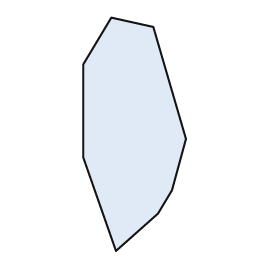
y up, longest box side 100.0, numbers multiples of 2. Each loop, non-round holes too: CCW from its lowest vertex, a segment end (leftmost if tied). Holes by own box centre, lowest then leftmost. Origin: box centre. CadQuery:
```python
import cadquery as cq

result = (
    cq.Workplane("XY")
    .moveTo(-8.0, -50.0)
    .lineTo(10.0, -34.0)
    .lineTo(16.0, -24.0)
    .lineTo(22.0, -2.0)
    .lineTo(8.0, 46.0)
    .lineTo(-10.0, 50.0)
    .lineTo(-22.0, 30.0)
    .lineTo(-22.0, -10.0)
    .close()
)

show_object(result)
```